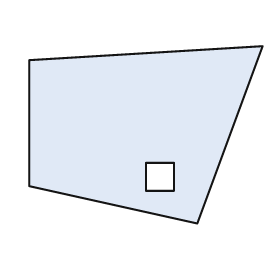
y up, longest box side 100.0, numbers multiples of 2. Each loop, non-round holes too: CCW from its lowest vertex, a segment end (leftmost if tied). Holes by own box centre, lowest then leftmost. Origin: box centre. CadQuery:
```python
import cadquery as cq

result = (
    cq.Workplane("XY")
    .moveTo(22.0, -38.0)
    .lineTo(50.0, 38.0)
    .lineTo(-50.0, 32.0)
    .lineTo(-50.0, -22.0)
    .close()
    .moveTo(0.0, -24.0)
    .lineTo(12.0, -24.0)
    .lineTo(12.0, -12.0)
    .lineTo(0.0, -12.0)
    .close()
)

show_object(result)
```